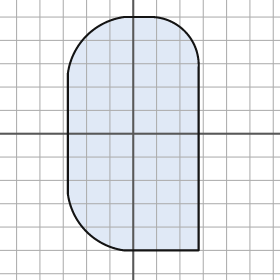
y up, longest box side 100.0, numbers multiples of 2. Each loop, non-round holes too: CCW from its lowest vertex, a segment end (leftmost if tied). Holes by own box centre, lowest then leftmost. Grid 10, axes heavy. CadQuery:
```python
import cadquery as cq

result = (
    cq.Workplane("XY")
    .moveTo(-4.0, -50.0)
    .lineTo(28.0, -50.0)
    .lineTo(28.0, 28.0)
    .threePointArc((22.0, 44.0), (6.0, 50.0))
    .lineTo(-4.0, 50.0)
    .threePointArc((-20.0, 42.0), (-28.0, 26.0))
    .lineTo(-28.0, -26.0)
    .threePointArc((-20.0, -42.0), (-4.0, -50.0))
    .close()
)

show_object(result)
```